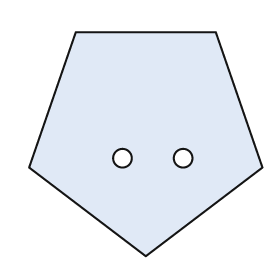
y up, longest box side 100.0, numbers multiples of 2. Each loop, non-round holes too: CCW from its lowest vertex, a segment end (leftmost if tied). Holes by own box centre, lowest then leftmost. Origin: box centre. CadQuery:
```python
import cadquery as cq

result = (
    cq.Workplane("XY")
    .moveTo(0.0, -48.0)
    .lineTo(50.0, -10.0)
    .lineTo(30.0, 48.0)
    .lineTo(-30.0, 48.0)
    .lineTo(-50.0, -10.0)
    .close()
    .moveTo(-10.0, -6.0)
    .circle(4.0)
    .moveTo(16.0, -6.0)
    .circle(4.0)
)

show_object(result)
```